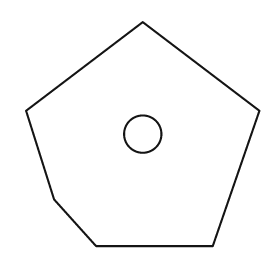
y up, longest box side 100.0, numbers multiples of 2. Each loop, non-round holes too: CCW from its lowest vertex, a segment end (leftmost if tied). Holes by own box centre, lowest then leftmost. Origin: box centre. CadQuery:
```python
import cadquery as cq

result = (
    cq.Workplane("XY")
    .moveTo(-20.0, -48.0)
    .lineTo(30.0, -48.0)
    .lineTo(50.0, 10.0)
    .lineTo(0.0, 48.0)
    .lineTo(-50.0, 10.0)
    .lineTo(-38.0, -28.0)
    .close()
    .moveTo(0.0, 0.0)
    .circle(8.0)
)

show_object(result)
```